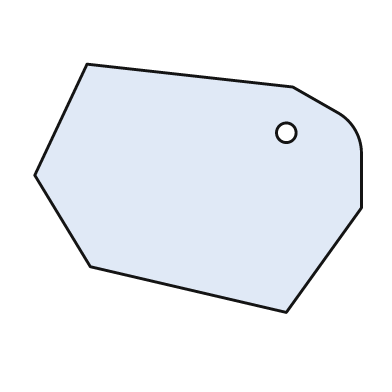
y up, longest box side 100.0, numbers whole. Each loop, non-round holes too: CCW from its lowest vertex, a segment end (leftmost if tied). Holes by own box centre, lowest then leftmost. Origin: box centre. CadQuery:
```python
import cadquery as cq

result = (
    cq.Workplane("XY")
    .moveTo(27.0, -38.0)
    .lineTo(50.0, -6.0)
    .lineTo(50.0, 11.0)
    .threePointArc((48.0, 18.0), (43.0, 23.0))
    .lineTo(29.0, 31.0)
    .lineTo(-34.0, 38.0)
    .lineTo(-50.0, 4.0)
    .lineTo(-33.0, -24.0)
    .close()
    .moveTo(27.0, 17.0)
    .circle(3.0)
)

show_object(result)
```